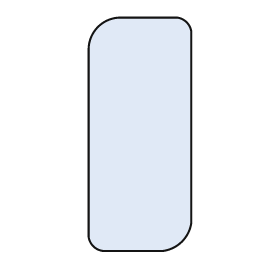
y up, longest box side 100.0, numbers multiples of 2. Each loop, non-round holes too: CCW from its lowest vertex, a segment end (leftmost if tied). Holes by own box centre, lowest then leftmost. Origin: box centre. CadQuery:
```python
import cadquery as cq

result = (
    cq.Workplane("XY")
    .moveTo(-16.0, -50.0)
    .lineTo(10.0, -50.0)
    .threePointArc((18.0, -46.0), (22.0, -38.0))
    .lineTo(22.0, 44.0)
    .threePointArc((20.0, 48.0), (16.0, 50.0))
    .lineTo(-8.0, 50.0)
    .threePointArc((-18.0, 46.0), (-22.0, 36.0))
    .lineTo(-22.0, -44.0)
    .threePointArc((-20.0, -48.0), (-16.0, -50.0))
    .close()
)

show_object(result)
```